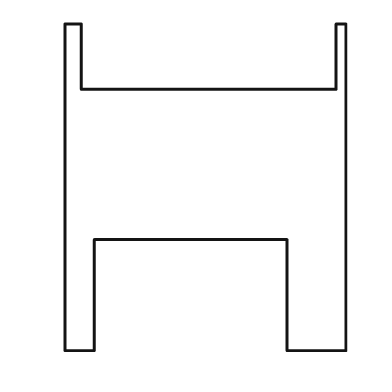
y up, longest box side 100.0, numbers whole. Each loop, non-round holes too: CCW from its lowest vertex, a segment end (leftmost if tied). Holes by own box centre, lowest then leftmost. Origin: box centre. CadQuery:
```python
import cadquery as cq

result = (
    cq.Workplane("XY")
    .moveTo(-43.0, -50.0)
    .lineTo(-34.0, -50.0)
    .lineTo(-34.0, -16.0)
    .lineTo(25.0, -16.0)
    .lineTo(25.0, -50.0)
    .lineTo(43.0, -50.0)
    .lineTo(43.0, 50.0)
    .lineTo(40.0, 50.0)
    .lineTo(40.0, 30.0)
    .lineTo(-38.0, 30.0)
    .lineTo(-38.0, 50.0)
    .lineTo(-43.0, 50.0)
    .close()
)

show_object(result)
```